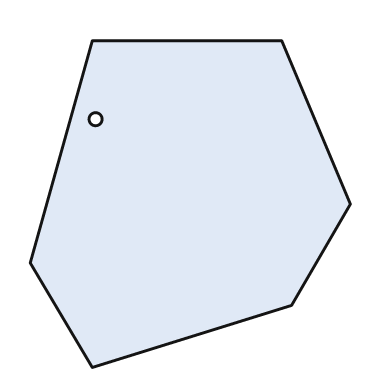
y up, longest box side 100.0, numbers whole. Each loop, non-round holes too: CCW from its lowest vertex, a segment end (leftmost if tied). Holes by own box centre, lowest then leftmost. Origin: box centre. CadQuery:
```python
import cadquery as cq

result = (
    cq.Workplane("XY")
    .moveTo(-30.0, -50.0)
    .lineTo(31.0, -31.0)
    .lineTo(49.0, 0.0)
    .lineTo(28.0, 50.0)
    .lineTo(-30.0, 50.0)
    .lineTo(-49.0, -18.0)
    .close()
    .moveTo(-29.0, 26.0)
    .circle(2.0)
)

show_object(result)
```